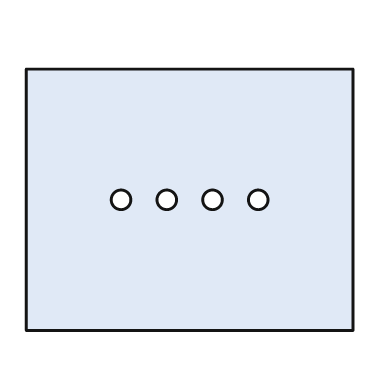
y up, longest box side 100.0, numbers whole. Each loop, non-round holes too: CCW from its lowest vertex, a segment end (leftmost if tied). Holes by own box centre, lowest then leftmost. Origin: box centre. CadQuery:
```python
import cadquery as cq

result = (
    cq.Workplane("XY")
    .moveTo(-50.0, -40.0)
    .lineTo(50.0, -40.0)
    .lineTo(50.0, 40.0)
    .lineTo(-50.0, 40.0)
    .close()
    .moveTo(-21.0, 0.0)
    .circle(3.0)
    .moveTo(-7.0, 0.0)
    .circle(3.0)
    .moveTo(7.0, 0.0)
    .circle(3.0)
    .moveTo(21.0, 0.0)
    .circle(3.0)
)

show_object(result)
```